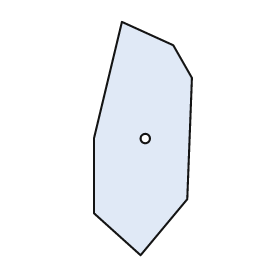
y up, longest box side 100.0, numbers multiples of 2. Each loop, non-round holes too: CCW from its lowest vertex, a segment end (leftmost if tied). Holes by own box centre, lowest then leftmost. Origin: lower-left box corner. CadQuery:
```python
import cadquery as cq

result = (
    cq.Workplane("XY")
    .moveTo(20.0, 0.0)
    .lineTo(40.0, 24.0)
    .lineTo(42.0, 76.0)
    .lineTo(34.0, 90.0)
    .lineTo(12.0, 100.0)
    .lineTo(0.0, 50.0)
    .lineTo(0.0, 18.0)
    .close()
    .moveTo(22.0, 50.0)
    .circle(2.0)
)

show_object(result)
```